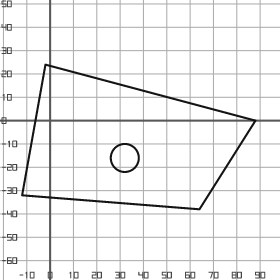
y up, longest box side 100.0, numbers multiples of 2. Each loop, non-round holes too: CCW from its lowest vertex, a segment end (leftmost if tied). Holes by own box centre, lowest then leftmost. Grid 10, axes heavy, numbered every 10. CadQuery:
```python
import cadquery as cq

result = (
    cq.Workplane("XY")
    .moveTo(64.0, -38.0)
    .lineTo(88.0, 0.0)
    .lineTo(-2.0, 24.0)
    .lineTo(-12.0, -32.0)
    .close()
    .moveTo(32.0, -16.0)
    .circle(6.0)
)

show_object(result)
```